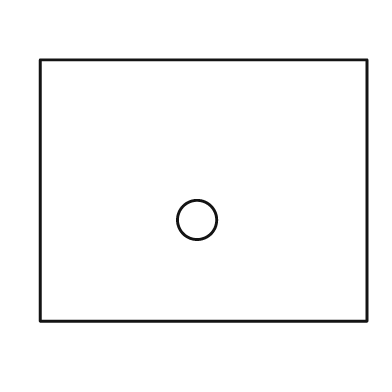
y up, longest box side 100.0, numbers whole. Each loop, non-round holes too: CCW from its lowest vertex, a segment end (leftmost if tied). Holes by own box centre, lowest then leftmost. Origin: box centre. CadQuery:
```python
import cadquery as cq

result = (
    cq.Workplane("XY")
    .moveTo(-50.0, -40.0)
    .lineTo(50.0, -40.0)
    .lineTo(50.0, 40.0)
    .lineTo(-50.0, 40.0)
    .close()
    .moveTo(-2.0, -9.0)
    .circle(6.0)
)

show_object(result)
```